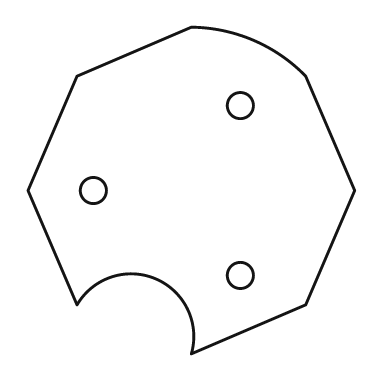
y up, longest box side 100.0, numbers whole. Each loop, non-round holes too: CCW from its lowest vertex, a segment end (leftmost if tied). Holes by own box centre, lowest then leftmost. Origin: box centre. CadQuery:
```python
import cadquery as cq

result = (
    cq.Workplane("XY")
    .moveTo(0.0, -50.0)
    .lineTo(35.0, -35.0)
    .lineTo(50.0, 0.0)
    .lineTo(35.0, 35.0)
    .threePointArc((19.0, 46.0), (0.0, 50.0))
    .lineTo(-35.0, 35.0)
    .lineTo(-50.0, 0.0)
    .lineTo(-35.0, -35.0)
    .threePointArc((-11.0, -27.0), (0.0, -50.0))
    .close()
    .moveTo(15.0, -26.0)
    .circle(4.0)
    .moveTo(-30.0, 0.0)
    .circle(4.0)
    .moveTo(15.0, 26.0)
    .circle(4.0)
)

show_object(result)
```